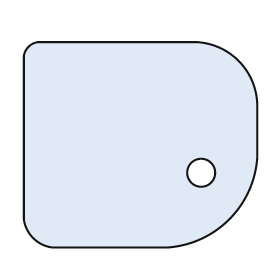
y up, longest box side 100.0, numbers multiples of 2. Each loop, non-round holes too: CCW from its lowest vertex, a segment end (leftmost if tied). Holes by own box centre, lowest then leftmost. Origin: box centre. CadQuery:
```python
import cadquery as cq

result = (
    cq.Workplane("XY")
    .moveTo(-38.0, -44.0)
    .lineTo(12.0, -44.0)
    .threePointArc((38.0, -32.0), (50.0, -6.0))
    .lineTo(50.0, 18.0)
    .threePointArc((42.0, 36.0), (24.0, 44.0))
    .lineTo(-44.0, 44.0)
    .threePointArc((-48.0, 42.0), (-50.0, 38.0))
    .lineTo(-50.0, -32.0)
    .threePointArc((-46.0, -40.0), (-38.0, -44.0))
    .close()
    .moveTo(26.0, -12.0)
    .circle(6.0)
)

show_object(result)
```